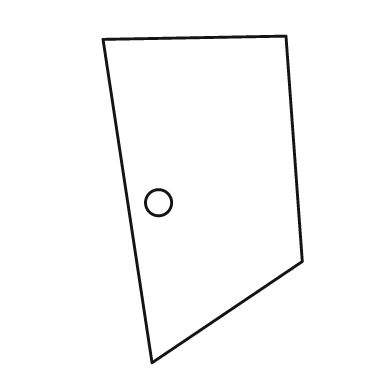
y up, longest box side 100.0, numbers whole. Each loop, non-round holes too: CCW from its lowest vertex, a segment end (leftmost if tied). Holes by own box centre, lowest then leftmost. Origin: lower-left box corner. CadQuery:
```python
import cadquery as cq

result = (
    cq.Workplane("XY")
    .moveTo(15.0, 0.0)
    .lineTo(61.0, 31.0)
    .lineTo(56.0, 100.0)
    .lineTo(0.0, 99.0)
    .close()
    .moveTo(17.0, 49.0)
    .circle(4.0)
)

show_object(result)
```